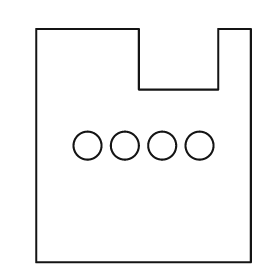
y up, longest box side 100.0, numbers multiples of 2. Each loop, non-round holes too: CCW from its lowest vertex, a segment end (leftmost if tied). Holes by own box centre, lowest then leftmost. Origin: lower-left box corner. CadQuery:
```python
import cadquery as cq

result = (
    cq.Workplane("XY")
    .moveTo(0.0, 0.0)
    .lineTo(92.0, 0.0)
    .lineTo(92.0, 100.0)
    .lineTo(78.0, 100.0)
    .lineTo(78.0, 74.0)
    .lineTo(44.0, 74.0)
    .lineTo(44.0, 100.0)
    .lineTo(0.0, 100.0)
    .close()
    .moveTo(22.0, 50.0)
    .circle(6.0)
    .moveTo(38.0, 50.0)
    .circle(6.0)
    .moveTo(54.0, 50.0)
    .circle(6.0)
    .moveTo(70.0, 50.0)
    .circle(6.0)
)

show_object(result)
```